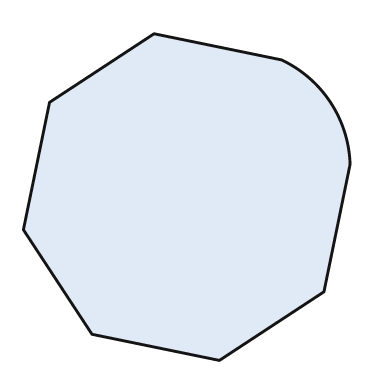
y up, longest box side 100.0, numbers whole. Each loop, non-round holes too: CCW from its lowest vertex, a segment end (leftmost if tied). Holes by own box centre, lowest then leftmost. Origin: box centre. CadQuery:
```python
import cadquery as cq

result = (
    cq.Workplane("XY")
    .moveTo(10.0, -50.0)
    .lineTo(42.0, -29.0)
    .lineTo(50.0, 10.0)
    .threePointArc((44.0, 29.0), (29.0, 42.0))
    .lineTo(-10.0, 50.0)
    .lineTo(-42.0, 29.0)
    .lineTo(-50.0, -10.0)
    .lineTo(-29.0, -42.0)
    .close()
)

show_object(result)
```